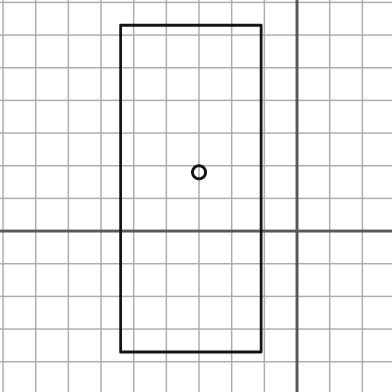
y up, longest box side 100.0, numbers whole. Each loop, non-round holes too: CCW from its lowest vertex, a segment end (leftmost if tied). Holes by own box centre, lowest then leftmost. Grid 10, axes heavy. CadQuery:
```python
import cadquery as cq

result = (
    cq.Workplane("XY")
    .moveTo(-54.0, -37.0)
    .lineTo(-11.0, -37.0)
    .lineTo(-11.0, 63.0)
    .lineTo(-54.0, 63.0)
    .close()
    .moveTo(-30.0, 18.0)
    .circle(2.0)
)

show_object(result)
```